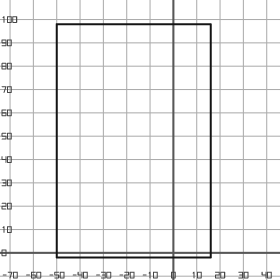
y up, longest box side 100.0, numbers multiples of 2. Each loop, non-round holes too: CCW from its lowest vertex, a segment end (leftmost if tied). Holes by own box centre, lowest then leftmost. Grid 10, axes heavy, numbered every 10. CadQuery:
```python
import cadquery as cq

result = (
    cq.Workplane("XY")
    .moveTo(-50.0, -2.0)
    .lineTo(16.0, -2.0)
    .lineTo(16.0, 98.0)
    .lineTo(-50.0, 98.0)
    .close()
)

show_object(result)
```